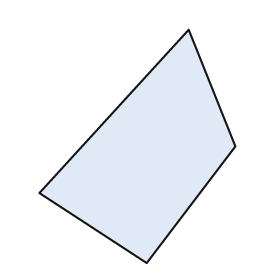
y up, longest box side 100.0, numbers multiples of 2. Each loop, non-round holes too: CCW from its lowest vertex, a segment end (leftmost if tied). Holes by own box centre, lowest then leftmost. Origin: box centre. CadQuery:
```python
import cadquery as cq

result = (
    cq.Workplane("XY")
    .moveTo(4.0, -50.0)
    .lineTo(42.0, 0.0)
    .lineTo(22.0, 50.0)
    .lineTo(-42.0, -20.0)
    .close()
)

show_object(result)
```